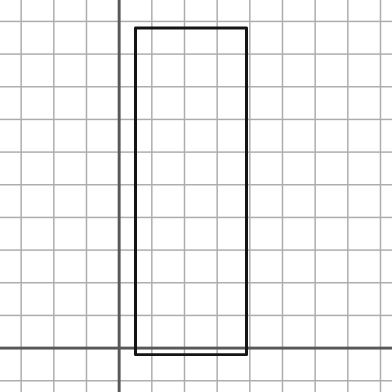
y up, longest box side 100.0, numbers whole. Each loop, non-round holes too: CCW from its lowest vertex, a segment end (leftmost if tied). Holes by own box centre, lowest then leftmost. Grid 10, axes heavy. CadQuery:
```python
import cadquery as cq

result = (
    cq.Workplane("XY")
    .moveTo(5.0, -2.0)
    .lineTo(39.0, -2.0)
    .lineTo(39.0, 98.0)
    .lineTo(5.0, 98.0)
    .close()
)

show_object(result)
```